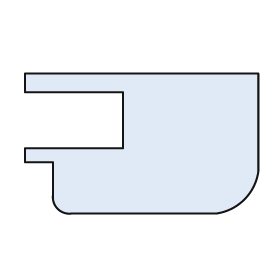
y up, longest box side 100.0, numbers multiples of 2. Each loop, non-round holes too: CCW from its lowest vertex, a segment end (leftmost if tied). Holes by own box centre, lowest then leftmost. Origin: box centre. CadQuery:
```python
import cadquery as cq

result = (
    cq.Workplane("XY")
    .moveTo(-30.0, -30.0)
    .lineTo(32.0, -30.0)
    .threePointArc((44.0, -24.0), (50.0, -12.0))
    .lineTo(50.0, 30.0)
    .lineTo(-50.0, 30.0)
    .lineTo(-50.0, 22.0)
    .lineTo(-8.0, 22.0)
    .lineTo(-8.0, -2.0)
    .lineTo(-50.0, -2.0)
    .lineTo(-50.0, -8.0)
    .lineTo(-38.0, -8.0)
    .lineTo(-38.0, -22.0)
    .threePointArc((-36.0, -28.0), (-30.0, -30.0))
    .close()
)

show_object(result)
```